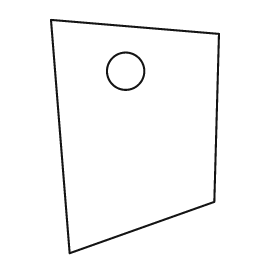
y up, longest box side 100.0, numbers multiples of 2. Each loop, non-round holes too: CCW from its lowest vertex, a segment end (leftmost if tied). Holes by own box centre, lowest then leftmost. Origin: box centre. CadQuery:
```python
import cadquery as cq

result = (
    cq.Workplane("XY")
    .moveTo(-28.0, -50.0)
    .lineTo(34.0, -28.0)
    .lineTo(36.0, 44.0)
    .lineTo(-36.0, 50.0)
    .close()
    .moveTo(-4.0, 28.0)
    .circle(8.0)
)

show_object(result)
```